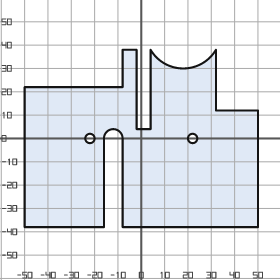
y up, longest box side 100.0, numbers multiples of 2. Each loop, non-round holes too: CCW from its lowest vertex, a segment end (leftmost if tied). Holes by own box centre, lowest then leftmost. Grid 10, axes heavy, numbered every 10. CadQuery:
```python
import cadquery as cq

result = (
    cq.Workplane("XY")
    .moveTo(-50.0, -38.0)
    .lineTo(-16.0, -38.0)
    .lineTo(-16.0, 0.0)
    .threePointArc((-12.0, 4.0), (-8.0, 0.0))
    .lineTo(-8.0, -38.0)
    .lineTo(50.0, -38.0)
    .lineTo(50.0, 12.0)
    .lineTo(32.0, 12.0)
    .lineTo(32.0, 38.0)
    .threePointArc((18.0, 30.0), (4.0, 38.0))
    .lineTo(4.0, 4.0)
    .lineTo(-2.0, 4.0)
    .lineTo(-2.0, 38.0)
    .lineTo(-8.0, 38.0)
    .lineTo(-8.0, 22.0)
    .lineTo(-50.0, 22.0)
    .close()
    .moveTo(-22.0, 0.0)
    .circle(2.0)
    .moveTo(22.0, 0.0)
    .circle(2.0)
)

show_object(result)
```